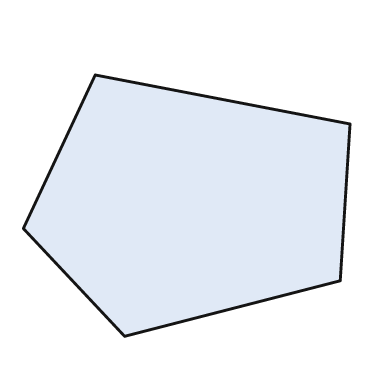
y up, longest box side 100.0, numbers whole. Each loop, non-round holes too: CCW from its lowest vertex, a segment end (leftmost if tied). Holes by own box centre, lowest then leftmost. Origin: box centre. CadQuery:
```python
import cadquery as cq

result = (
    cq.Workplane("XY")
    .moveTo(-19.0, -40.0)
    .lineTo(47.0, -23.0)
    .lineTo(50.0, 25.0)
    .lineTo(-28.0, 40.0)
    .lineTo(-50.0, -7.0)
    .close()
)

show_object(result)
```